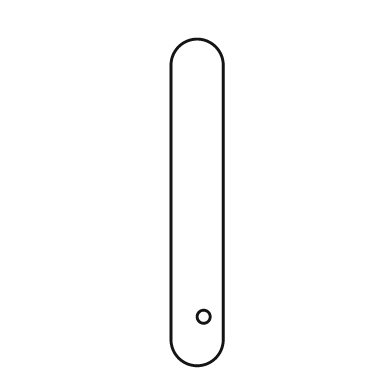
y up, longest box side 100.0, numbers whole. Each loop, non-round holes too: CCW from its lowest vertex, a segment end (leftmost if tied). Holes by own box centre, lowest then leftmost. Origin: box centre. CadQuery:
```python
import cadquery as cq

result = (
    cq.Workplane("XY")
    .moveTo(-8.0, -42.0)
    .threePointArc((0.0, -50.0), (8.0, -42.0))
    .lineTo(8.0, 42.0)
    .threePointArc((0.0, 50.0), (-8.0, 42.0))
    .close()
    .moveTo(2.0, -35.0)
    .circle(2.0)
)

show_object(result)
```